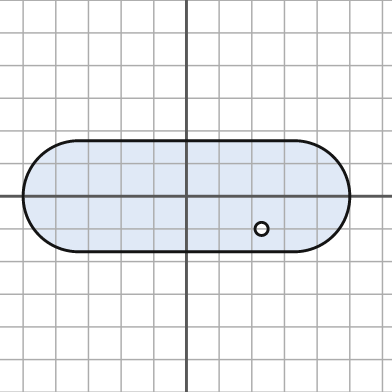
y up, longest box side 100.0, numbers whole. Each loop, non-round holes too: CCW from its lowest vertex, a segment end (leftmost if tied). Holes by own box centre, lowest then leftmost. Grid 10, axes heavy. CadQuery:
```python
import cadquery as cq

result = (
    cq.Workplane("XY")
    .moveTo(-33.0, -17.0)
    .lineTo(33.0, -17.0)
    .threePointArc((50.0, 0.0), (33.0, 17.0))
    .lineTo(-33.0, 17.0)
    .threePointArc((-50.0, 0.0), (-33.0, -17.0))
    .close()
    .moveTo(23.0, -10.0)
    .circle(2.0)
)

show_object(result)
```